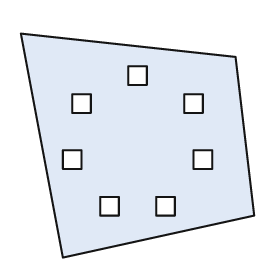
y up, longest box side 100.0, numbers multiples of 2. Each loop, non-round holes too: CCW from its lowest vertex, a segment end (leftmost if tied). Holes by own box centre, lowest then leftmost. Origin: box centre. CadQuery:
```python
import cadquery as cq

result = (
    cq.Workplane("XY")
    .moveTo(-32.0, -48.0)
    .lineTo(50.0, -30.0)
    .lineTo(42.0, 38.0)
    .lineTo(-50.0, 48.0)
    .close()
    .moveTo(-16.0, -30.0)
    .lineTo(-8.0, -30.0)
    .lineTo(-8.0, -22.0)
    .lineTo(-16.0, -22.0)
    .close()
    .moveTo(8.0, -30.0)
    .lineTo(16.0, -30.0)
    .lineTo(16.0, -22.0)
    .lineTo(8.0, -22.0)
    .close()
    .moveTo(-32.0, -10.0)
    .lineTo(-24.0, -10.0)
    .lineTo(-24.0, -2.0)
    .lineTo(-32.0, -2.0)
    .close()
    .moveTo(24.0, -10.0)
    .lineTo(32.0, -10.0)
    .lineTo(32.0, -2.0)
    .lineTo(24.0, -2.0)
    .close()
    .moveTo(-28.0, 14.0)
    .lineTo(-20.0, 14.0)
    .lineTo(-20.0, 22.0)
    .lineTo(-28.0, 22.0)
    .close()
    .moveTo(20.0, 14.0)
    .lineTo(28.0, 14.0)
    .lineTo(28.0, 22.0)
    .lineTo(20.0, 22.0)
    .close()
    .moveTo(-4.0, 26.0)
    .lineTo(4.0, 26.0)
    .lineTo(4.0, 34.0)
    .lineTo(-4.0, 34.0)
    .close()
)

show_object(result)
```